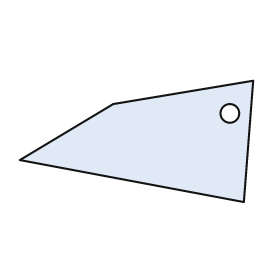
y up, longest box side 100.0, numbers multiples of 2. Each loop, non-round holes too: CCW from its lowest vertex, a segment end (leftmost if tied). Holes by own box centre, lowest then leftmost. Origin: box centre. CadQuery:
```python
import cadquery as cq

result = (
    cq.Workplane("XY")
    .moveTo(46.0, -26.0)
    .lineTo(50.0, 26.0)
    .lineTo(-10.0, 16.0)
    .lineTo(-50.0, -8.0)
    .close()
    .moveTo(40.0, 12.0)
    .circle(4.0)
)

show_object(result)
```